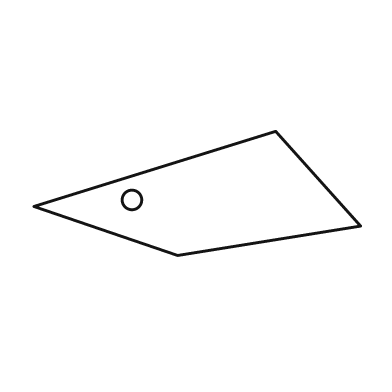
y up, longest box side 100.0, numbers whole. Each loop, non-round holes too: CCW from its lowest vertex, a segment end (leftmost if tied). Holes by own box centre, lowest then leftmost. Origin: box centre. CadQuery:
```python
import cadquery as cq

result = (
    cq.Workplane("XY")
    .moveTo(-6.0, -19.0)
    .lineTo(50.0, -10.0)
    .lineTo(24.0, 19.0)
    .lineTo(-50.0, -4.0)
    .close()
    .moveTo(-20.0, -2.0)
    .circle(3.0)
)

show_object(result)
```